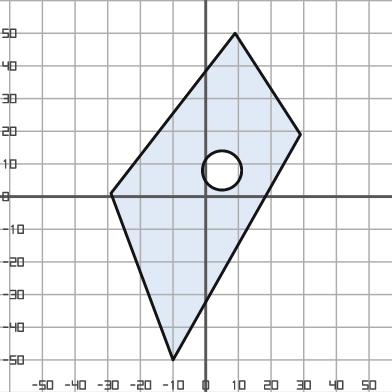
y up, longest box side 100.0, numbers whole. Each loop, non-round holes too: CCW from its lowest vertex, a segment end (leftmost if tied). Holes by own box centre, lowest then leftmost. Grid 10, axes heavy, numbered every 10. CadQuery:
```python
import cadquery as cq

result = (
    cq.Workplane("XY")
    .moveTo(-10.0, -50.0)
    .lineTo(29.0, 19.0)
    .lineTo(9.0, 50.0)
    .lineTo(-29.0, 1.0)
    .close()
    .moveTo(5.0, 8.0)
    .circle(6.0)
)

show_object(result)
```